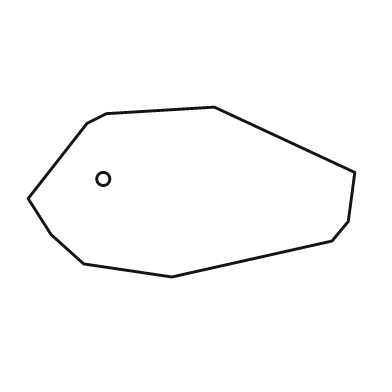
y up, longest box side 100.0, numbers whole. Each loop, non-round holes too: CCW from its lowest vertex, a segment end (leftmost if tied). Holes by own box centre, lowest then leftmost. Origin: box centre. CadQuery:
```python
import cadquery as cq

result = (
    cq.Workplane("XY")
    .moveTo(-6.0, -26.0)
    .lineTo(43.0, -15.0)
    .lineTo(48.0, -9.0)
    .lineTo(50.0, 6.0)
    .lineTo(7.0, 26.0)
    .lineTo(-26.0, 24.0)
    .lineTo(-32.0, 21.0)
    .lineTo(-50.0, -2.0)
    .lineTo(-43.0, -13.0)
    .lineTo(-33.0, -22.0)
    .close()
    .moveTo(-27.0, 4.0)
    .circle(2.0)
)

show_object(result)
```